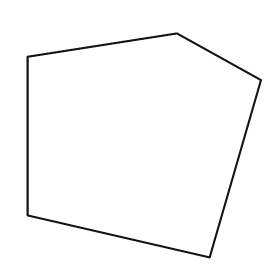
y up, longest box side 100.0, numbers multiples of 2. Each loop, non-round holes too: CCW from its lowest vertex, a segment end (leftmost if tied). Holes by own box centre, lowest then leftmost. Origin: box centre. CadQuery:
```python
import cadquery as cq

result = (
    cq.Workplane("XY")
    .moveTo(28.0, -48.0)
    .lineTo(50.0, 28.0)
    .lineTo(14.0, 48.0)
    .lineTo(-50.0, 38.0)
    .lineTo(-50.0, -30.0)
    .close()
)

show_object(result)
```